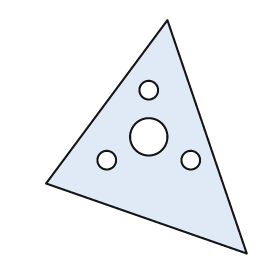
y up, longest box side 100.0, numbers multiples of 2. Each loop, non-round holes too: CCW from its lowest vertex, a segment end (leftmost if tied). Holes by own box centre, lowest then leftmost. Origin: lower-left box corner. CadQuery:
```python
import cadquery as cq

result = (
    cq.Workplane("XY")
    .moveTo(86.0, 0.0)
    .lineTo(52.0, 100.0)
    .lineTo(0.0, 30.0)
    .close()
    .moveTo(26.0, 40.0)
    .circle(4.0)
    .moveTo(62.0, 40.0)
    .circle(4.0)
    .moveTo(44.0, 50.0)
    .circle(8.0)
    .moveTo(44.0, 70.0)
    .circle(4.0)
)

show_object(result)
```